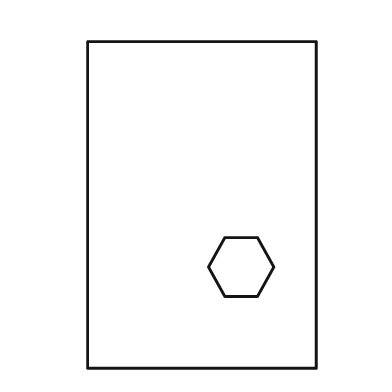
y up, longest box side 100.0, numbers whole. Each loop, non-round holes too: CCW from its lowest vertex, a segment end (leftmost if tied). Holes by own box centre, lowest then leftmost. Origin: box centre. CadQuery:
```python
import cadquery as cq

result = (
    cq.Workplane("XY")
    .moveTo(-35.0, -50.0)
    .lineTo(35.0, -50.0)
    .lineTo(35.0, 50.0)
    .lineTo(-35.0, 50.0)
    .close()
    .moveTo(7.0, -28.0)
    .lineTo(17.0, -28.0)
    .lineTo(22.0, -19.0)
    .lineTo(17.0, -10.0)
    .lineTo(7.0, -10.0)
    .lineTo(2.0, -19.0)
    .close()
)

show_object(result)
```